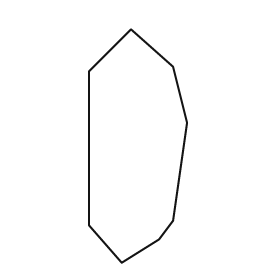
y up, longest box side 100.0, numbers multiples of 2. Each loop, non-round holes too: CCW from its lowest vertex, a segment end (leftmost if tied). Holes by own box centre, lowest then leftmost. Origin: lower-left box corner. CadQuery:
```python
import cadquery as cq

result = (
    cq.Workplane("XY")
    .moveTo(14.0, 0.0)
    .lineTo(30.0, 10.0)
    .lineTo(36.0, 18.0)
    .lineTo(42.0, 60.0)
    .lineTo(36.0, 84.0)
    .lineTo(18.0, 100.0)
    .lineTo(0.0, 82.0)
    .lineTo(0.0, 16.0)
    .close()
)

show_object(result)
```